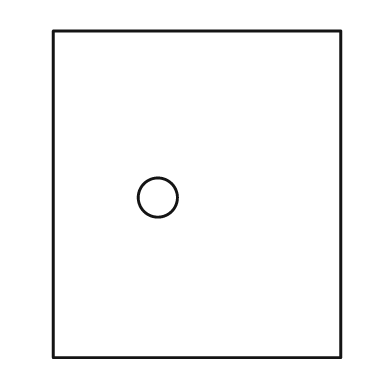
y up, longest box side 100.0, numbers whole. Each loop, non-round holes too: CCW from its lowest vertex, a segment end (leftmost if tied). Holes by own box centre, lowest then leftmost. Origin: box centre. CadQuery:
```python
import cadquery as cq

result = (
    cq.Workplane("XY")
    .moveTo(-44.0, -50.0)
    .lineTo(44.0, -50.0)
    .lineTo(44.0, 50.0)
    .lineTo(-44.0, 50.0)
    .close()
    .moveTo(-12.0, -1.0)
    .circle(6.0)
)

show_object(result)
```